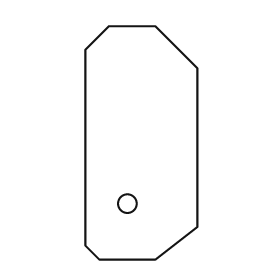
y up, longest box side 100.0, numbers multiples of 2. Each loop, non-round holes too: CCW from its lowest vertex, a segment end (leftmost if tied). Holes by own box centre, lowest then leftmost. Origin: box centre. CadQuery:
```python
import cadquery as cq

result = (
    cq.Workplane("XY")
    .moveTo(-18.0, -50.0)
    .lineTo(6.0, -50.0)
    .lineTo(24.0, -36.0)
    .lineTo(24.0, 32.0)
    .lineTo(6.0, 50.0)
    .lineTo(-14.0, 50.0)
    .lineTo(-24.0, 40.0)
    .lineTo(-24.0, -44.0)
    .close()
    .moveTo(-6.0, -26.0)
    .circle(4.0)
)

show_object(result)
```